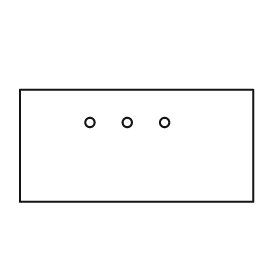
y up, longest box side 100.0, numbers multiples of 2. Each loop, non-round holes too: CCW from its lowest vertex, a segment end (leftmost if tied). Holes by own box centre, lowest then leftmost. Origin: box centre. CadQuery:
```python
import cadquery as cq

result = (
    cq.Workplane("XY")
    .moveTo(-50.0, -24.0)
    .lineTo(50.0, -24.0)
    .lineTo(50.0, 24.0)
    .lineTo(-50.0, 24.0)
    .close()
    .moveTo(-20.0, 10.0)
    .circle(2.0)
    .moveTo(-4.0, 10.0)
    .circle(2.0)
    .moveTo(12.0, 10.0)
    .circle(2.0)
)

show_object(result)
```